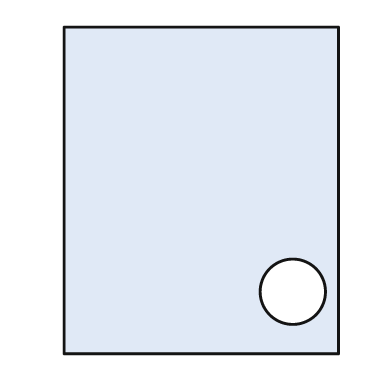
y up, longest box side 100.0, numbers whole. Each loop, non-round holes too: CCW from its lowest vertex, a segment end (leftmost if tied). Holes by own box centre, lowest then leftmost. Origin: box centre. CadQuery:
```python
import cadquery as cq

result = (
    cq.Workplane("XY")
    .moveTo(-42.0, -50.0)
    .lineTo(42.0, -50.0)
    .lineTo(42.0, 50.0)
    .lineTo(-42.0, 50.0)
    .close()
    .moveTo(28.0, -31.0)
    .circle(10.0)
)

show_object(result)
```